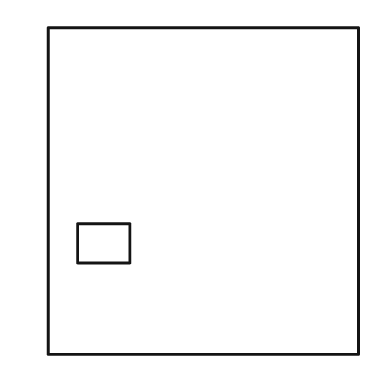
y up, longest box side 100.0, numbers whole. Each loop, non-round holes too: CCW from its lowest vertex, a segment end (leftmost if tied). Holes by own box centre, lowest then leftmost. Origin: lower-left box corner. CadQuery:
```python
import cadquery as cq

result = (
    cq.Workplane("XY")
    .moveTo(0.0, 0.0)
    .lineTo(95.0, 0.0)
    .lineTo(95.0, 100.0)
    .lineTo(0.0, 100.0)
    .close()
    .moveTo(9.0, 28.0)
    .lineTo(25.0, 28.0)
    .lineTo(25.0, 40.0)
    .lineTo(9.0, 40.0)
    .close()
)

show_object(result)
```